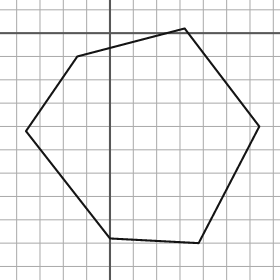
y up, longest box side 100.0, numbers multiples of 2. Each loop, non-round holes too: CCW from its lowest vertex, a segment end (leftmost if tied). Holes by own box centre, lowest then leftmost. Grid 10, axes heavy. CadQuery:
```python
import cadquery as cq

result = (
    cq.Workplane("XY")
    .moveTo(38.0, -90.0)
    .lineTo(64.0, -40.0)
    .lineTo(32.0, 2.0)
    .lineTo(-14.0, -10.0)
    .lineTo(-36.0, -42.0)
    .lineTo(0.0, -88.0)
    .close()
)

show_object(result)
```